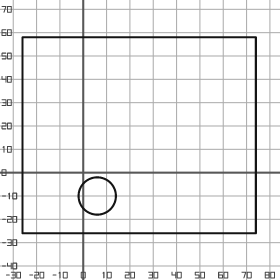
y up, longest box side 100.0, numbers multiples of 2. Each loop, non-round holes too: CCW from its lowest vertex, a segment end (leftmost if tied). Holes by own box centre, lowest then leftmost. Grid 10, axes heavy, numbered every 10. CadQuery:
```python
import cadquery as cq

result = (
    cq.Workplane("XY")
    .moveTo(-26.0, -26.0)
    .lineTo(74.0, -26.0)
    .lineTo(74.0, 58.0)
    .lineTo(-26.0, 58.0)
    .close()
    .moveTo(6.0, -10.0)
    .circle(8.0)
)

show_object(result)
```